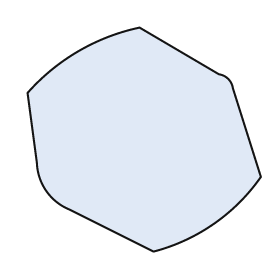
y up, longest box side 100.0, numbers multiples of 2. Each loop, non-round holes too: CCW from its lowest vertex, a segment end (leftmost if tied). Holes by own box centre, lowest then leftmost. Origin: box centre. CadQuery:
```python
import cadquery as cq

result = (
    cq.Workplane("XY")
    .moveTo(4.0, -48.0)
    .threePointArc((30.0, -36.0), (50.0, -16.0))
    .lineTo(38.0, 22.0)
    .threePointArc((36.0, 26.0), (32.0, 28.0))
    .lineTo(-2.0, 48.0)
    .threePointArc((-28.0, 38.0), (-50.0, 20.0))
    .lineTo(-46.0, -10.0)
    .threePointArc((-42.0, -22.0), (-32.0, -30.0))
    .close()
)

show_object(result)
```